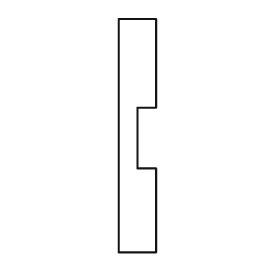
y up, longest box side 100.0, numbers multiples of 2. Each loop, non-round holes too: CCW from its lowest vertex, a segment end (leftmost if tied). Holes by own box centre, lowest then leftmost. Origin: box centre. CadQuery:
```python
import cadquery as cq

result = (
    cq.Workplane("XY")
    .moveTo(-8.0, -50.0)
    .lineTo(8.0, -50.0)
    .lineTo(8.0, -14.0)
    .lineTo(0.0, -14.0)
    .lineTo(0.0, 12.0)
    .lineTo(8.0, 12.0)
    .lineTo(8.0, 50.0)
    .lineTo(-8.0, 50.0)
    .close()
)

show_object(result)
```